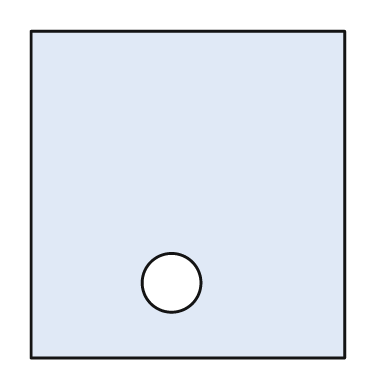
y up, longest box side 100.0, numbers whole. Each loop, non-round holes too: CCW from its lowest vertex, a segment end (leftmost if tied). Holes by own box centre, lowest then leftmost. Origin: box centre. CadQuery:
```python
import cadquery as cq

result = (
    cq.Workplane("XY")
    .moveTo(-48.0, -50.0)
    .lineTo(48.0, -50.0)
    .lineTo(48.0, 50.0)
    .lineTo(-48.0, 50.0)
    .close()
    .moveTo(-5.0, -27.0)
    .circle(9.0)
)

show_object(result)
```